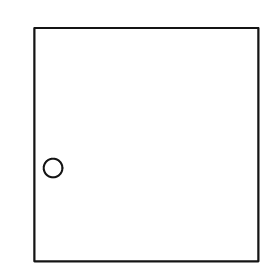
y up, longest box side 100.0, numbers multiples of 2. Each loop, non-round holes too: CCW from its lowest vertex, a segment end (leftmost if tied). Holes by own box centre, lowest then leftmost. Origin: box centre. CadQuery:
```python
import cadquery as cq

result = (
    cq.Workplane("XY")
    .moveTo(-48.0, -50.0)
    .lineTo(48.0, -50.0)
    .lineTo(48.0, 50.0)
    .lineTo(-48.0, 50.0)
    .close()
    .moveTo(-40.0, -10.0)
    .circle(4.0)
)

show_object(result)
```